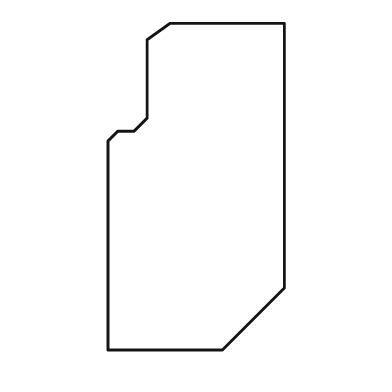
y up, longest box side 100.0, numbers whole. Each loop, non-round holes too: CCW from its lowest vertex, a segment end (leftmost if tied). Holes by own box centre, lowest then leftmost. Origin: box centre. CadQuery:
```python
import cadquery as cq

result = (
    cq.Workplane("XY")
    .moveTo(-27.0, -50.0)
    .lineTo(8.0, -50.0)
    .lineTo(27.0, -31.0)
    .lineTo(27.0, 50.0)
    .lineTo(-8.0, 50.0)
    .lineTo(-15.0, 45.0)
    .lineTo(-15.0, 21.0)
    .lineTo(-19.0, 17.0)
    .lineTo(-24.0, 17.0)
    .lineTo(-27.0, 14.0)
    .close()
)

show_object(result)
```